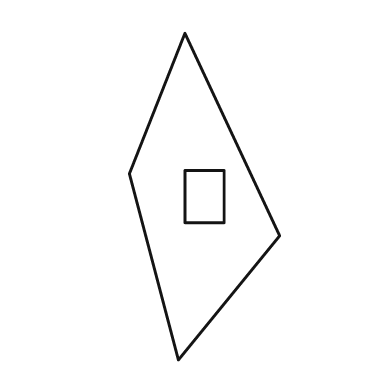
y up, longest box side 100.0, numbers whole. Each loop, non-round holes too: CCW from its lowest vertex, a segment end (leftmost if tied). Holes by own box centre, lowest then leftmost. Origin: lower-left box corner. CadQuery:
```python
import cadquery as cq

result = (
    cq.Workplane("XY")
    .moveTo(15.0, 0.0)
    .lineTo(46.0, 38.0)
    .lineTo(17.0, 100.0)
    .lineTo(0.0, 57.0)
    .close()
    .moveTo(17.0, 42.0)
    .lineTo(29.0, 42.0)
    .lineTo(29.0, 58.0)
    .lineTo(17.0, 58.0)
    .close()
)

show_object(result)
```